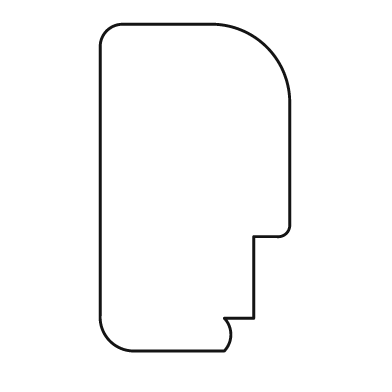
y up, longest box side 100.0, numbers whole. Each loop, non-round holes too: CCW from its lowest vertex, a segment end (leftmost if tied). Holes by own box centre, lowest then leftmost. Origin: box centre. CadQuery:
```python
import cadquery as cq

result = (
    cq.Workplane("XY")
    .moveTo(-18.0, -50.0)
    .lineTo(9.0, -50.0)
    .threePointArc((11.0, -45.0), (9.0, -40.0))
    .lineTo(18.0, -40.0)
    .lineTo(18.0, -15.0)
    .lineTo(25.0, -15.0)
    .threePointArc((28.0, -14.0), (29.0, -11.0))
    .lineTo(29.0, 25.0)
    .threePointArc((22.0, 43.0), (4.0, 50.0))
    .lineTo(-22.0, 50.0)
    .threePointArc((-27.0, 48.0), (-29.0, 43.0))
    .lineTo(-29.0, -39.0)
    .threePointArc((-26.0, -47.0), (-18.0, -50.0))
    .close()
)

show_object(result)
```